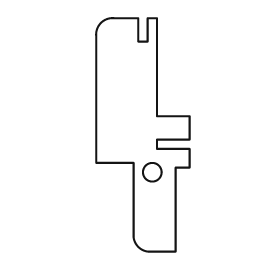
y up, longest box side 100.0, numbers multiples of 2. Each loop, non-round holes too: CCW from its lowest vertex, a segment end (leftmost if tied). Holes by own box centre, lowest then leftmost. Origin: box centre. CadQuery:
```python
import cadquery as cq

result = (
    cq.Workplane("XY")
    .moveTo(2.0, -50.0)
    .lineTo(14.0, -50.0)
    .lineTo(14.0, -14.0)
    .lineTo(20.0, -14.0)
    .lineTo(20.0, -6.0)
    .lineTo(6.0, -6.0)
    .lineTo(6.0, -2.0)
    .lineTo(20.0, -2.0)
    .lineTo(20.0, 8.0)
    .lineTo(6.0, 8.0)
    .lineTo(6.0, 50.0)
    .lineTo(2.0, 50.0)
    .lineTo(2.0, 40.0)
    .lineTo(-2.0, 40.0)
    .lineTo(-2.0, 50.0)
    .lineTo(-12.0, 50.0)
    .threePointArc((-18.0, 48.0), (-20.0, 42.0))
    .lineTo(-20.0, -12.0)
    .lineTo(-4.0, -12.0)
    .lineTo(-4.0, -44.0)
    .threePointArc((-2.0, -48.0), (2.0, -50.0))
    .close()
    .moveTo(4.0, -16.0)
    .circle(4.0)
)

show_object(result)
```